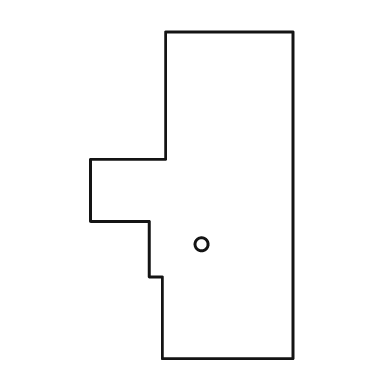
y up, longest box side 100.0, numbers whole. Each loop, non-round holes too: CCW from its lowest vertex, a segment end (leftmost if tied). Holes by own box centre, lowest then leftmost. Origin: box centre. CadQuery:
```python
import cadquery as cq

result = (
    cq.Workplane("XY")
    .moveTo(-9.0, -50.0)
    .lineTo(31.0, -50.0)
    .lineTo(31.0, 50.0)
    .lineTo(-8.0, 50.0)
    .lineTo(-8.0, 11.0)
    .lineTo(-31.0, 11.0)
    .lineTo(-31.0, -8.0)
    .lineTo(-13.0, -8.0)
    .lineTo(-13.0, -25.0)
    .lineTo(-9.0, -25.0)
    .close()
    .moveTo(3.0, -15.0)
    .circle(2.0)
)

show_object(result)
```